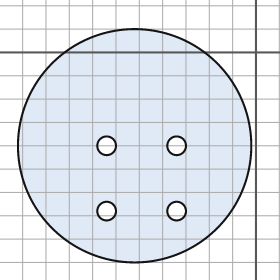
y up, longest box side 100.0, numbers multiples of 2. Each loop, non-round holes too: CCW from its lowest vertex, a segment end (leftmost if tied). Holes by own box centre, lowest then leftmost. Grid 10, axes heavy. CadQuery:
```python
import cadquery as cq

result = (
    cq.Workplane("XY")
    .moveTo(-52.0, -40.0)
    .circle(50.0)
    .moveTo(-64.0, -68.0)
    .circle(4.0)
    .moveTo(-34.0, -68.0)
    .circle(4.0)
    .moveTo(-64.0, -40.0)
    .circle(4.0)
    .moveTo(-34.0, -40.0)
    .circle(4.0)
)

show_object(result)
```